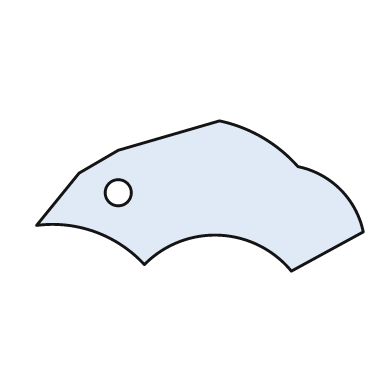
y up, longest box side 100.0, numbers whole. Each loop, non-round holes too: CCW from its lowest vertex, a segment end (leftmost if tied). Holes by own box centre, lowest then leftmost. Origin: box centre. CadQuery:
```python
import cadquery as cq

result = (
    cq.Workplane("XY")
    .moveTo(28.0, -23.0)
    .lineTo(50.0, -11.0)
    .threePointArc((43.0, 2.0), (30.0, 9.0))
    .threePointArc((19.0, 18.0), (6.0, 23.0))
    .lineTo(-25.0, 14.0)
    .lineTo(-37.0, 7.0)
    .lineTo(-50.0, -9.0)
    .threePointArc((-32.0, -11.0), (-17.0, -21.0))
    .threePointArc((6.0, -12.0), (28.0, -23.0))
    .close()
    .moveTo(-25.0, 1.0)
    .circle(4.0)
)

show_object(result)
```